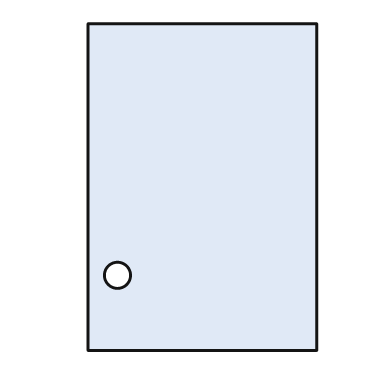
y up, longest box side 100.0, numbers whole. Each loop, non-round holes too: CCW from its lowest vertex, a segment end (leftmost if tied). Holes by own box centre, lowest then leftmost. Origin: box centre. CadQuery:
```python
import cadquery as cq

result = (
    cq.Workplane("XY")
    .moveTo(-35.0, -50.0)
    .lineTo(35.0, -50.0)
    .lineTo(35.0, 50.0)
    .lineTo(-35.0, 50.0)
    .close()
    .moveTo(-26.0, -27.0)
    .circle(4.0)
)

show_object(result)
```